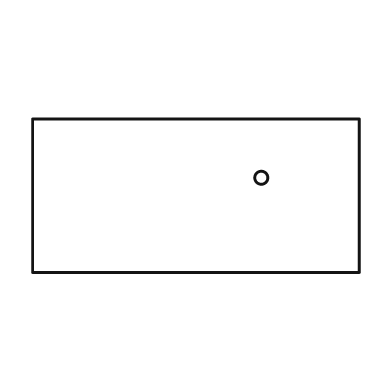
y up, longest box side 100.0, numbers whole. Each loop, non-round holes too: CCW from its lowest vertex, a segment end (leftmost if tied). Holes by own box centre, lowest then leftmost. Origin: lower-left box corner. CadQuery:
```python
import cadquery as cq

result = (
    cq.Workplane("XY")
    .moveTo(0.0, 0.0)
    .lineTo(100.0, 0.0)
    .lineTo(100.0, 47.0)
    .lineTo(0.0, 47.0)
    .close()
    .moveTo(70.0, 29.0)
    .circle(2.0)
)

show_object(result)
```